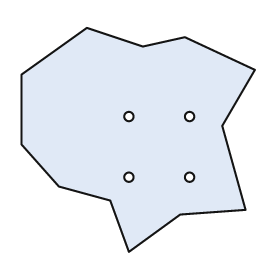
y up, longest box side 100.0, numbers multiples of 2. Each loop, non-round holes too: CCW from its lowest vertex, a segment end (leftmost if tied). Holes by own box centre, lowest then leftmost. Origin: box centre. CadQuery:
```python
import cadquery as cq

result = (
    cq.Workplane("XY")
    .moveTo(-4.0, -48.0)
    .lineTo(18.0, -32.0)
    .lineTo(46.0, -30.0)
    .lineTo(36.0, 6.0)
    .lineTo(50.0, 30.0)
    .lineTo(20.0, 44.0)
    .lineTo(2.0, 40.0)
    .lineTo(-22.0, 48.0)
    .lineTo(-50.0, 28.0)
    .lineTo(-50.0, -2.0)
    .lineTo(-34.0, -20.0)
    .lineTo(-12.0, -26.0)
    .close()
    .moveTo(-4.0, -16.0)
    .circle(2.0)
    .moveTo(22.0, -16.0)
    .circle(2.0)
    .moveTo(-4.0, 10.0)
    .circle(2.0)
    .moveTo(22.0, 10.0)
    .circle(2.0)
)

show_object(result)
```